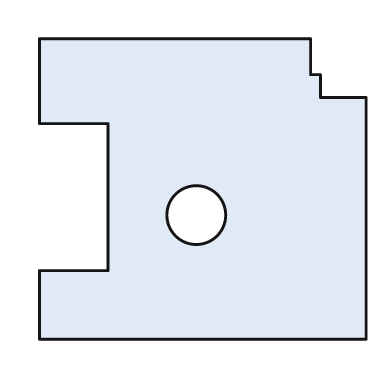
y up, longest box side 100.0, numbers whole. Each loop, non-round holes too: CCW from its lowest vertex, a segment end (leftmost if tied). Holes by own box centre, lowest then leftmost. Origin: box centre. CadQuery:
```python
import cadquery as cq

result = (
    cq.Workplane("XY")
    .moveTo(-50.0, -46.0)
    .lineTo(50.0, -46.0)
    .lineTo(50.0, 28.0)
    .lineTo(36.0, 28.0)
    .lineTo(36.0, 35.0)
    .lineTo(33.0, 35.0)
    .lineTo(33.0, 46.0)
    .lineTo(-50.0, 46.0)
    .lineTo(-50.0, 20.0)
    .lineTo(-29.0, 20.0)
    .lineTo(-29.0, -25.0)
    .lineTo(-50.0, -25.0)
    .close()
    .moveTo(-2.0, -8.0)
    .circle(9.0)
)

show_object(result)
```